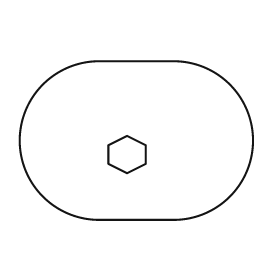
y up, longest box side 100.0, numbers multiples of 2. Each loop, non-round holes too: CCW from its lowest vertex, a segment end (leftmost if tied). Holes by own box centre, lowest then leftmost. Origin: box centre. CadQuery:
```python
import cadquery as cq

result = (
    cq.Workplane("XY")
    .moveTo(-16.0, -34.0)
    .lineTo(16.0, -34.0)
    .threePointArc((50.0, 0.0), (16.0, 34.0))
    .lineTo(-16.0, 34.0)
    .threePointArc((-50.0, 0.0), (-16.0, -34.0))
    .close()
    .moveTo(-4.0, -14.0)
    .lineTo(4.0, -10.0)
    .lineTo(4.0, -2.0)
    .lineTo(-4.0, 2.0)
    .lineTo(-12.0, -2.0)
    .lineTo(-12.0, -10.0)
    .close()
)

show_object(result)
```